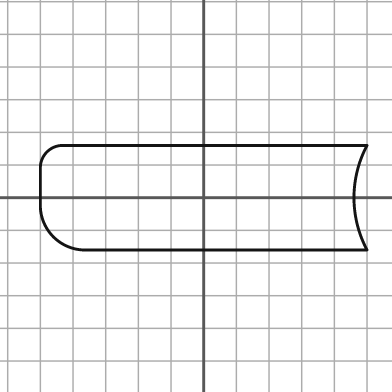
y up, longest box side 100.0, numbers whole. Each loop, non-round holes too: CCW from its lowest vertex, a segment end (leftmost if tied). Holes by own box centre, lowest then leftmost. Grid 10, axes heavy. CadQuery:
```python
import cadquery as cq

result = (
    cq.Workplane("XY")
    .moveTo(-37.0, -16.0)
    .lineTo(50.0, -16.0)
    .threePointArc((46.0, 0.0), (50.0, 16.0))
    .lineTo(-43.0, 16.0)
    .threePointArc((-48.0, 14.0), (-50.0, 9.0))
    .lineTo(-50.0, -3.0)
    .threePointArc((-46.0, -12.0), (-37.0, -16.0))
    .close()
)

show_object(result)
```